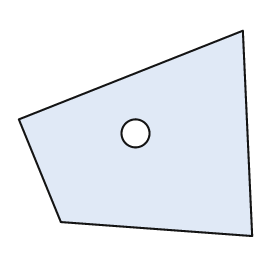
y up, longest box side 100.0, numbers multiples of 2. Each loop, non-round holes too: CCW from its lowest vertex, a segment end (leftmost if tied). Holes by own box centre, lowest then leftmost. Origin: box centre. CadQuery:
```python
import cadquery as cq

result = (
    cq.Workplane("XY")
    .moveTo(50.0, -44.0)
    .lineTo(46.0, 44.0)
    .lineTo(-50.0, 6.0)
    .lineTo(-32.0, -38.0)
    .close()
    .moveTo(0.0, 0.0)
    .circle(6.0)
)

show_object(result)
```